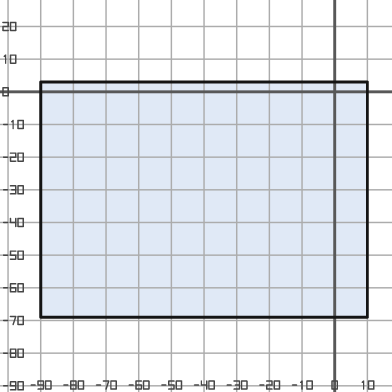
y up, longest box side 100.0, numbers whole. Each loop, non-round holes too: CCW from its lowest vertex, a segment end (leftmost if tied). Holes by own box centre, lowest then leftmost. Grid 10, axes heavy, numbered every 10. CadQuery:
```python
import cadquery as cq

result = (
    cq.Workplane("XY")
    .moveTo(-90.0, -69.0)
    .lineTo(10.0, -69.0)
    .lineTo(10.0, 3.0)
    .lineTo(-90.0, 3.0)
    .close()
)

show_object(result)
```